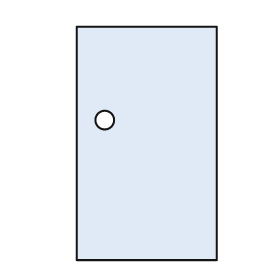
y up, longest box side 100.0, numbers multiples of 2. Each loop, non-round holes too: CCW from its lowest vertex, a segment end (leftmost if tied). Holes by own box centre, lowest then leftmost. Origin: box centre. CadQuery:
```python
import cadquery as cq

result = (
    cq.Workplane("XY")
    .moveTo(-30.0, -50.0)
    .lineTo(30.0, -50.0)
    .lineTo(30.0, 50.0)
    .lineTo(-30.0, 50.0)
    .close()
    .moveTo(-18.0, 10.0)
    .circle(4.0)
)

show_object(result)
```